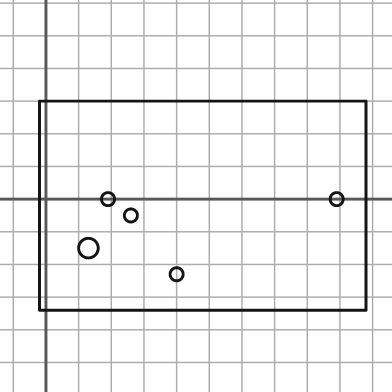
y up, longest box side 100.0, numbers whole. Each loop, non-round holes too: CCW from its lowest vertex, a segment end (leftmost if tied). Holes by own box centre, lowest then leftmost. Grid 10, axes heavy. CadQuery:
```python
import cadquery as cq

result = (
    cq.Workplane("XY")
    .moveTo(-2.0, -34.0)
    .lineTo(98.0, -34.0)
    .lineTo(98.0, 30.0)
    .lineTo(-2.0, 30.0)
    .close()
    .moveTo(40.0, -23.0)
    .circle(2.0)
    .moveTo(13.0, -15.0)
    .circle(3.0)
    .moveTo(26.0, -5.0)
    .circle(2.0)
    .moveTo(19.0, 0.0)
    .circle(2.0)
    .moveTo(89.0, 0.0)
    .circle(2.0)
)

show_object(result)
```